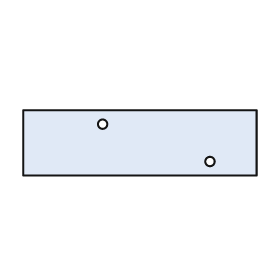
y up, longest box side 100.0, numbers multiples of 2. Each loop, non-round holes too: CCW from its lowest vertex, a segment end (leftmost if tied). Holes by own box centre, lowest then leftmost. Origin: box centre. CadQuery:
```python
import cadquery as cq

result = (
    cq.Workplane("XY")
    .moveTo(-50.0, -14.0)
    .lineTo(50.0, -14.0)
    .lineTo(50.0, 14.0)
    .lineTo(-50.0, 14.0)
    .close()
    .moveTo(30.0, -8.0)
    .circle(2.0)
    .moveTo(-16.0, 8.0)
    .circle(2.0)
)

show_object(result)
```